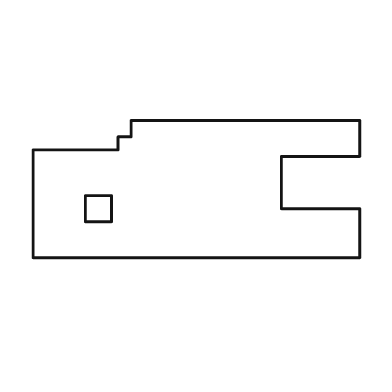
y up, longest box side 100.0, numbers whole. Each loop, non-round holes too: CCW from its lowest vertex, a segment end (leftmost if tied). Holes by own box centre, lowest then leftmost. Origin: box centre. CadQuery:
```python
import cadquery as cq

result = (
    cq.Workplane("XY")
    .moveTo(-50.0, -21.0)
    .lineTo(50.0, -21.0)
    .lineTo(50.0, -6.0)
    .lineTo(26.0, -6.0)
    .lineTo(26.0, 10.0)
    .lineTo(50.0, 10.0)
    .lineTo(50.0, 21.0)
    .lineTo(-20.0, 21.0)
    .lineTo(-20.0, 16.0)
    .lineTo(-24.0, 16.0)
    .lineTo(-24.0, 12.0)
    .lineTo(-50.0, 12.0)
    .close()
    .moveTo(-34.0, -10.0)
    .lineTo(-26.0, -10.0)
    .lineTo(-26.0, -2.0)
    .lineTo(-34.0, -2.0)
    .close()
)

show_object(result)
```